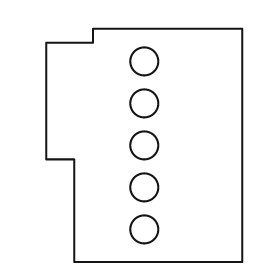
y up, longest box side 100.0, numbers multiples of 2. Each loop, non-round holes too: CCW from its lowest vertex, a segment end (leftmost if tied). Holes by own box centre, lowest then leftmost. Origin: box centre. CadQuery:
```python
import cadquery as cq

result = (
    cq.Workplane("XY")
    .moveTo(-30.0, -50.0)
    .lineTo(42.0, -50.0)
    .lineTo(42.0, 50.0)
    .lineTo(-22.0, 50.0)
    .lineTo(-22.0, 44.0)
    .lineTo(-42.0, 44.0)
    .lineTo(-42.0, -6.0)
    .lineTo(-30.0, -6.0)
    .close()
    .moveTo(0.0, -36.0)
    .circle(6.0)
    .moveTo(0.0, -18.0)
    .circle(6.0)
    .moveTo(0.0, 0.0)
    .circle(6.0)
    .moveTo(0.0, 18.0)
    .circle(6.0)
    .moveTo(0.0, 36.0)
    .circle(6.0)
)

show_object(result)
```